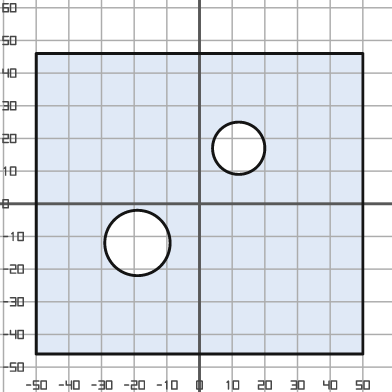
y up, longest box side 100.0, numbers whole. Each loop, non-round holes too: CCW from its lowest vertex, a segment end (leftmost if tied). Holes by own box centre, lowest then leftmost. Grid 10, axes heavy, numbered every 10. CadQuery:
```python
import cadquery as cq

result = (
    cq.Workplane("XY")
    .moveTo(-50.0, -46.0)
    .lineTo(50.0, -46.0)
    .lineTo(50.0, 46.0)
    .lineTo(-50.0, 46.0)
    .close()
    .moveTo(-19.0, -12.0)
    .circle(10.0)
    .moveTo(12.0, 17.0)
    .circle(8.0)
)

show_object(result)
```